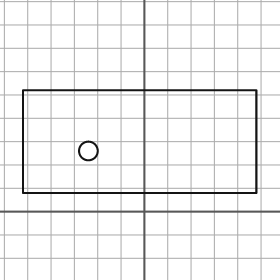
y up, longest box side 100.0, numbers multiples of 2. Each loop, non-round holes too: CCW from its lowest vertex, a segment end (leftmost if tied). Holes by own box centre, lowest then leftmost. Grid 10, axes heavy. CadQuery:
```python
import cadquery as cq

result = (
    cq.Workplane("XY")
    .moveTo(-52.0, 8.0)
    .lineTo(48.0, 8.0)
    .lineTo(48.0, 52.0)
    .lineTo(-52.0, 52.0)
    .close()
    .moveTo(-24.0, 26.0)
    .circle(4.0)
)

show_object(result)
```